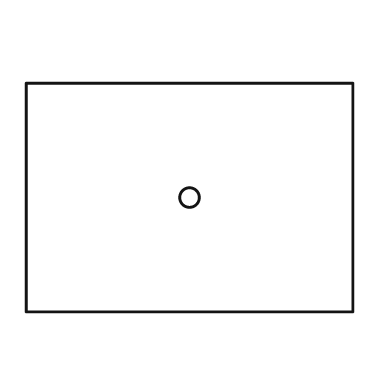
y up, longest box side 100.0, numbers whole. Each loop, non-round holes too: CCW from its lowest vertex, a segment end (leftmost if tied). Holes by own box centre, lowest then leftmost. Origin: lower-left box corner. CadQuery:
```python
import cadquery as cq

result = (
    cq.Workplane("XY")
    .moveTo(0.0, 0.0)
    .lineTo(100.0, 0.0)
    .lineTo(100.0, 70.0)
    .lineTo(0.0, 70.0)
    .close()
    .moveTo(50.0, 35.0)
    .circle(3.0)
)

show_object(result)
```